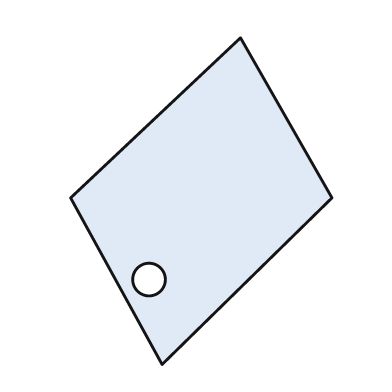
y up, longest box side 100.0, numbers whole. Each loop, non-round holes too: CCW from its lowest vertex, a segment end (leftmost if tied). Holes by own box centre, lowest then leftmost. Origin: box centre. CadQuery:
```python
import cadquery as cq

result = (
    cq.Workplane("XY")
    .moveTo(-12.0, -50.0)
    .lineTo(40.0, 1.0)
    .lineTo(12.0, 50.0)
    .lineTo(-40.0, 1.0)
    .close()
    .moveTo(-16.0, -24.0)
    .circle(5.0)
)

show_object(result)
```